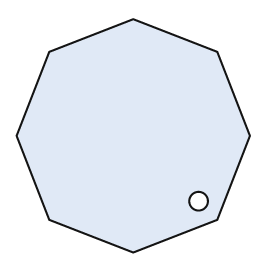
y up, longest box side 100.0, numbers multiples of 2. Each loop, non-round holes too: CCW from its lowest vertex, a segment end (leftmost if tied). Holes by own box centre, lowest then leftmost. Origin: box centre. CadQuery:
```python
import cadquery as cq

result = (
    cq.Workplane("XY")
    .moveTo(0.0, -50.0)
    .lineTo(36.0, -36.0)
    .lineTo(50.0, 0.0)
    .lineTo(36.0, 36.0)
    .lineTo(0.0, 50.0)
    .lineTo(-36.0, 36.0)
    .lineTo(-50.0, 0.0)
    .lineTo(-36.0, -36.0)
    .close()
    .moveTo(28.0, -28.0)
    .circle(4.0)
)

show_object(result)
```